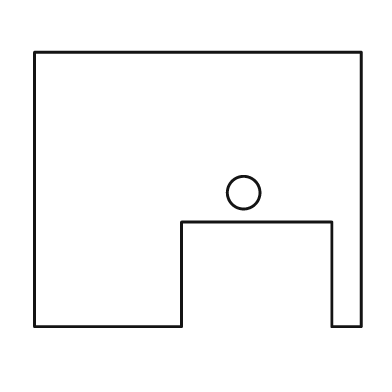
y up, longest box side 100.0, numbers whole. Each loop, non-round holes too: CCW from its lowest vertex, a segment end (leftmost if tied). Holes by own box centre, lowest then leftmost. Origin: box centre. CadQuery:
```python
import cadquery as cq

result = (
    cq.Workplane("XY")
    .moveTo(-50.0, -42.0)
    .lineTo(-5.0, -42.0)
    .lineTo(-5.0, -10.0)
    .lineTo(41.0, -10.0)
    .lineTo(41.0, -42.0)
    .lineTo(50.0, -42.0)
    .lineTo(50.0, 42.0)
    .lineTo(-50.0, 42.0)
    .close()
    .moveTo(14.0, -1.0)
    .circle(5.0)
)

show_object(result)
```